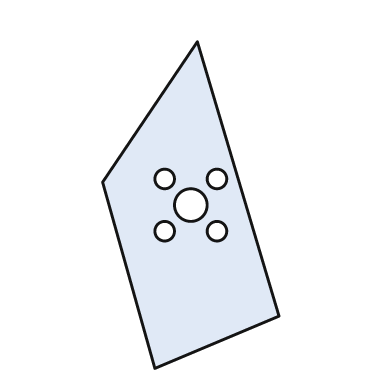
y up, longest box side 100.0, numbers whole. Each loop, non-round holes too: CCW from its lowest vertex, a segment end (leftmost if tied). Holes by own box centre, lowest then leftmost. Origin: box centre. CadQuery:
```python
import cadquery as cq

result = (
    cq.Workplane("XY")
    .moveTo(-11.0, -50.0)
    .lineTo(27.0, -34.0)
    .lineTo(2.0, 50.0)
    .lineTo(-27.0, 7.0)
    .close()
    .moveTo(-8.0, -8.0)
    .circle(3.0)
    .moveTo(8.0, -8.0)
    .circle(3.0)
    .moveTo(0.0, 0.0)
    .circle(5.0)
    .moveTo(-8.0, 8.0)
    .circle(3.0)
    .moveTo(8.0, 8.0)
    .circle(3.0)
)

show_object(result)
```